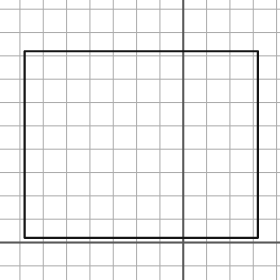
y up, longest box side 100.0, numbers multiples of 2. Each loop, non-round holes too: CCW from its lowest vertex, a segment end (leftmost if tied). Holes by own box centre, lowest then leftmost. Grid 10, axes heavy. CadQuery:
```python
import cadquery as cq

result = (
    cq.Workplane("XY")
    .moveTo(-68.0, 2.0)
    .lineTo(32.0, 2.0)
    .lineTo(32.0, 82.0)
    .lineTo(-68.0, 82.0)
    .close()
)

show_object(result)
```